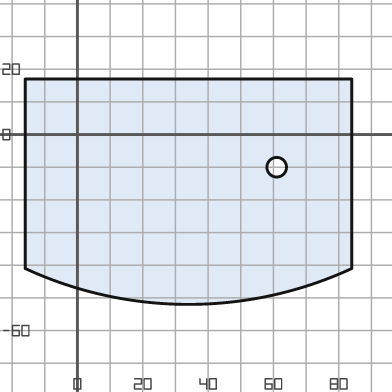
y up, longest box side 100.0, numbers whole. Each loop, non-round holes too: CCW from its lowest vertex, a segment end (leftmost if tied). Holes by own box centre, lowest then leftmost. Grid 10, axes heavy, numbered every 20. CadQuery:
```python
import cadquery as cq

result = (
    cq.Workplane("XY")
    .moveTo(-16.0, -41.0)
    .threePointArc((34.0, -52.0), (84.0, -41.0))
    .lineTo(84.0, 17.0)
    .lineTo(-16.0, 17.0)
    .close()
    .moveTo(61.0, -10.0)
    .circle(3.0)
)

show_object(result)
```